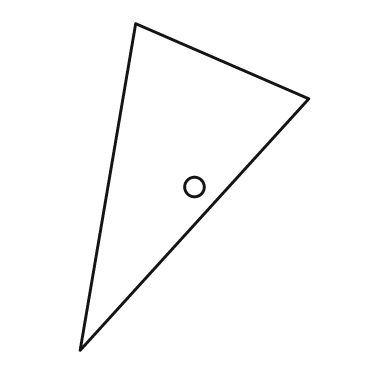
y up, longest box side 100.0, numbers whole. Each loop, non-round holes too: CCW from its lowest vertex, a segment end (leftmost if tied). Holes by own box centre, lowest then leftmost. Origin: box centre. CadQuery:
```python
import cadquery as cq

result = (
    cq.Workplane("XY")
    .moveTo(-35.0, -50.0)
    .lineTo(35.0, 27.0)
    .lineTo(-18.0, 50.0)
    .close()
    .moveTo(0.0, 0.0)
    .circle(3.0)
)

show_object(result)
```